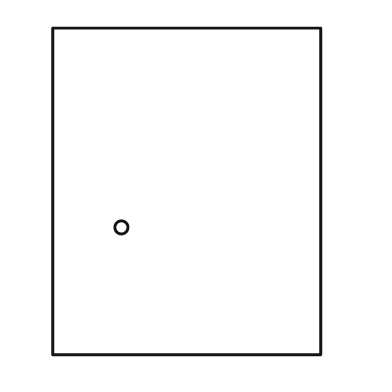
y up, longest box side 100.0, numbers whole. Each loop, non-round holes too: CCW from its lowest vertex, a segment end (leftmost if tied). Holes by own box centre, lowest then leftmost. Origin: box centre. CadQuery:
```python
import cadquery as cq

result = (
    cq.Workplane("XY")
    .moveTo(-41.0, -50.0)
    .lineTo(41.0, -50.0)
    .lineTo(41.0, 50.0)
    .lineTo(-41.0, 50.0)
    .close()
    .moveTo(-20.0, -11.0)
    .circle(2.0)
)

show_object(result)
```